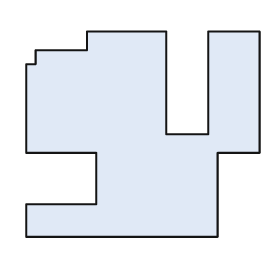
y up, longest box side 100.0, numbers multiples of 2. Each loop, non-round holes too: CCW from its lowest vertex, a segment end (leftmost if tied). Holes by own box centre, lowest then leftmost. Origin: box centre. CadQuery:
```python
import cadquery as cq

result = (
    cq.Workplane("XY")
    .moveTo(-50.0, -44.0)
    .lineTo(32.0, -44.0)
    .lineTo(32.0, -8.0)
    .lineTo(50.0, -8.0)
    .lineTo(50.0, 44.0)
    .lineTo(28.0, 44.0)
    .lineTo(28.0, 0.0)
    .lineTo(10.0, 0.0)
    .lineTo(10.0, 44.0)
    .lineTo(-24.0, 44.0)
    .lineTo(-24.0, 36.0)
    .lineTo(-46.0, 36.0)
    .lineTo(-46.0, 30.0)
    .lineTo(-50.0, 30.0)
    .lineTo(-50.0, -8.0)
    .lineTo(-20.0, -8.0)
    .lineTo(-20.0, -30.0)
    .lineTo(-50.0, -30.0)
    .close()
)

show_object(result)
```